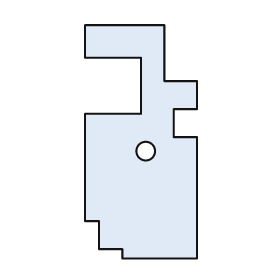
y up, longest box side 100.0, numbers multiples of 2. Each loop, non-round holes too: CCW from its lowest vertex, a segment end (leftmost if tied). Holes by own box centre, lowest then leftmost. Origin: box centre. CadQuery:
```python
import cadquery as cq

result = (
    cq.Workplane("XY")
    .moveTo(-8.0, -50.0)
    .lineTo(24.0, -50.0)
    .lineTo(24.0, 2.0)
    .lineTo(14.0, 2.0)
    .lineTo(14.0, 14.0)
    .lineTo(24.0, 14.0)
    .lineTo(24.0, 26.0)
    .lineTo(10.0, 26.0)
    .lineTo(10.0, 50.0)
    .lineTo(-24.0, 50.0)
    .lineTo(-24.0, 36.0)
    .lineTo(0.0, 36.0)
    .lineTo(0.0, 12.0)
    .lineTo(-24.0, 12.0)
    .lineTo(-24.0, -34.0)
    .lineTo(-18.0, -34.0)
    .lineTo(-18.0, -46.0)
    .lineTo(-8.0, -46.0)
    .close()
    .moveTo(2.0, -4.0)
    .circle(4.0)
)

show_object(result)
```